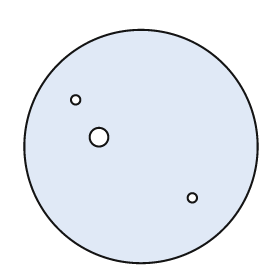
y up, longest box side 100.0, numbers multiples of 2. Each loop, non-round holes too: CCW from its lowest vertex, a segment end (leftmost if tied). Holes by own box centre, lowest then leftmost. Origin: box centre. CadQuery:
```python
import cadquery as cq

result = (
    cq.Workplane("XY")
    .moveTo(0.0, 0.0)
    .circle(50.0)
    .moveTo(22.0, -22.0)
    .circle(2.0)
    .moveTo(-18.0, 4.0)
    .circle(4.0)
    .moveTo(-28.0, 20.0)
    .circle(2.0)
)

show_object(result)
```